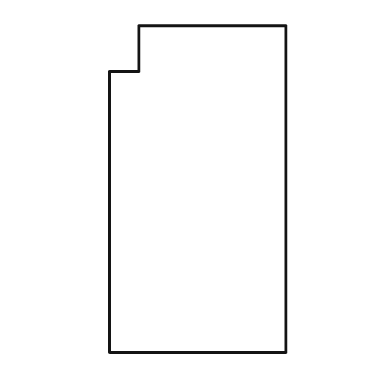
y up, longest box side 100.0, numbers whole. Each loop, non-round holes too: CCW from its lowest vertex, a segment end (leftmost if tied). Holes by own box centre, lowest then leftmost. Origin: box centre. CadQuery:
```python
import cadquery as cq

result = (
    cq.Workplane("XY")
    .moveTo(-27.0, -50.0)
    .lineTo(27.0, -50.0)
    .lineTo(27.0, 50.0)
    .lineTo(-18.0, 50.0)
    .lineTo(-18.0, 36.0)
    .lineTo(-27.0, 36.0)
    .close()
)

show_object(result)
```